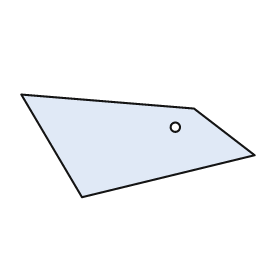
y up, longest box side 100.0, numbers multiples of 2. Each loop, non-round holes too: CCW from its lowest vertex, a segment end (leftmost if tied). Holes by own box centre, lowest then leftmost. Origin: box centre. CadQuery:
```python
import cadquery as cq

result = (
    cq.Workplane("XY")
    .moveTo(-24.0, -22.0)
    .lineTo(50.0, -4.0)
    .lineTo(24.0, 16.0)
    .lineTo(-50.0, 22.0)
    .close()
    .moveTo(16.0, 8.0)
    .circle(2.0)
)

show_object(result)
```